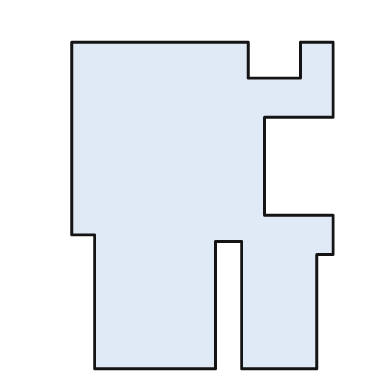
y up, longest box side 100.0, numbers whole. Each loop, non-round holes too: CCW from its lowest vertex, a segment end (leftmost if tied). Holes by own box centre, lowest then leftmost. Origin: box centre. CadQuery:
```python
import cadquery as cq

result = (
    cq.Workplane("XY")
    .moveTo(-33.0, -50.0)
    .lineTo(4.0, -50.0)
    .lineTo(4.0, -11.0)
    .lineTo(12.0, -11.0)
    .lineTo(12.0, -50.0)
    .lineTo(35.0, -50.0)
    .lineTo(35.0, -15.0)
    .lineTo(40.0, -15.0)
    .lineTo(40.0, -3.0)
    .lineTo(19.0, -3.0)
    .lineTo(19.0, 27.0)
    .lineTo(40.0, 27.0)
    .lineTo(40.0, 50.0)
    .lineTo(30.0, 50.0)
    .lineTo(30.0, 39.0)
    .lineTo(14.0, 39.0)
    .lineTo(14.0, 50.0)
    .lineTo(-40.0, 50.0)
    .lineTo(-40.0, -9.0)
    .lineTo(-33.0, -9.0)
    .close()
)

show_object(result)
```